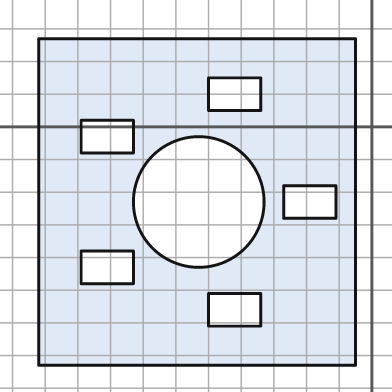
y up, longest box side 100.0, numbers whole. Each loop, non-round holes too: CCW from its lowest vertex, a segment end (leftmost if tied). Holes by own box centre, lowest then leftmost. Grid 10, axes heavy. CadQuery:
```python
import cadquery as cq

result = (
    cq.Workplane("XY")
    .moveTo(-102.0, -73.0)
    .lineTo(-5.0, -73.0)
    .lineTo(-5.0, 27.0)
    .lineTo(-102.0, 27.0)
    .close()
    .moveTo(-50.0, -61.0)
    .lineTo(-34.0, -61.0)
    .lineTo(-34.0, -51.0)
    .lineTo(-50.0, -51.0)
    .close()
    .moveTo(-89.0, -48.0)
    .lineTo(-73.0, -48.0)
    .lineTo(-73.0, -38.0)
    .lineTo(-89.0, -38.0)
    .close()
    .moveTo(-53.0, -23.0)
    .circle(20.0)
    .moveTo(-27.0, -28.0)
    .lineTo(-11.0, -28.0)
    .lineTo(-11.0, -18.0)
    .lineTo(-27.0, -18.0)
    .close()
    .moveTo(-89.0, -8.0)
    .lineTo(-73.0, -8.0)
    .lineTo(-73.0, 2.0)
    .lineTo(-89.0, 2.0)
    .close()
    .moveTo(-50.0, 5.0)
    .lineTo(-34.0, 5.0)
    .lineTo(-34.0, 15.0)
    .lineTo(-50.0, 15.0)
    .close()
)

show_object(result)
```